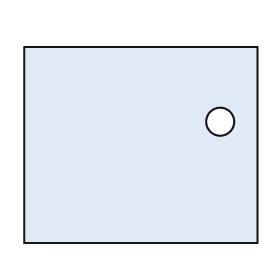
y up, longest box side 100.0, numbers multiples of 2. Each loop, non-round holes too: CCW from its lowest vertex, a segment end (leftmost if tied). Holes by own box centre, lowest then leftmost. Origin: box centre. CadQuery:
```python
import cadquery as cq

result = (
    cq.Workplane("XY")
    .moveTo(-50.0, -42.0)
    .lineTo(50.0, -42.0)
    .lineTo(50.0, 42.0)
    .lineTo(-50.0, 42.0)
    .close()
    .moveTo(34.0, 10.0)
    .circle(6.0)
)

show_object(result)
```